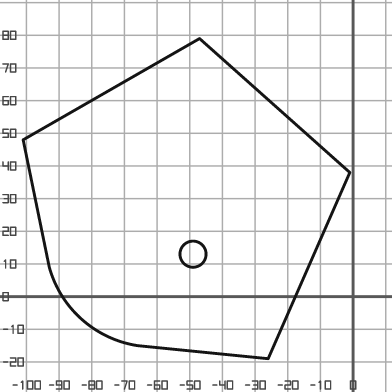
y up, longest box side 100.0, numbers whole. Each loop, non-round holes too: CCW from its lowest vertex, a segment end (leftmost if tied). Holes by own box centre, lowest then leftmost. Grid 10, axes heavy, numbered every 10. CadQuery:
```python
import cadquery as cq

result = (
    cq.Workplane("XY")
    .moveTo(-26.0, -19.0)
    .lineTo(-1.0, 38.0)
    .lineTo(-47.0, 79.0)
    .lineTo(-101.0, 48.0)
    .lineTo(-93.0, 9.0)
    .threePointArc((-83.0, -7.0), (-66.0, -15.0))
    .close()
    .moveTo(-49.0, 13.0)
    .circle(4.0)
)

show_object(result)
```